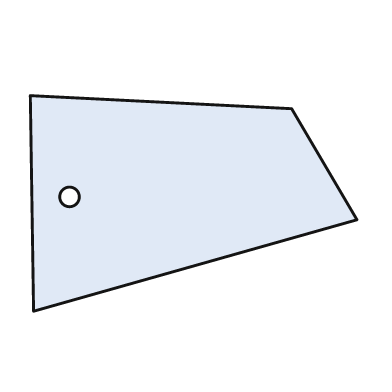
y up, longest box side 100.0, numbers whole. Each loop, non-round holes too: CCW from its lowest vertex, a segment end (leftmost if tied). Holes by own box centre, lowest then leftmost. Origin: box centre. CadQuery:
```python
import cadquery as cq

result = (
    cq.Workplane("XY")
    .moveTo(-49.0, -33.0)
    .lineTo(50.0, -5.0)
    .lineTo(30.0, 29.0)
    .lineTo(-50.0, 33.0)
    .close()
    .moveTo(-38.0, 2.0)
    .circle(3.0)
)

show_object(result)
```